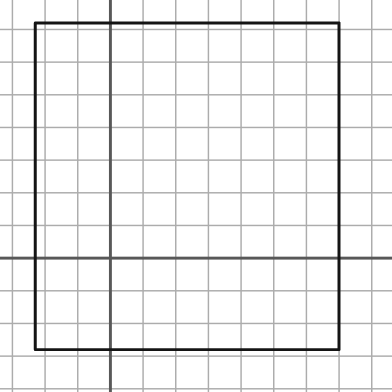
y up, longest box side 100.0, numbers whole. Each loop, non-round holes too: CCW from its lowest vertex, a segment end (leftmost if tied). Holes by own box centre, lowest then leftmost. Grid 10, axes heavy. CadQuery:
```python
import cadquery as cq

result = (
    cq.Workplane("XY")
    .moveTo(-23.0, -28.0)
    .lineTo(70.0, -28.0)
    .lineTo(70.0, 72.0)
    .lineTo(-23.0, 72.0)
    .close()
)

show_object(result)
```